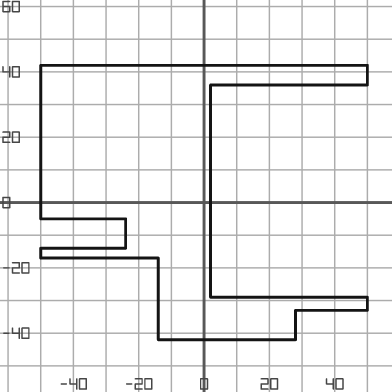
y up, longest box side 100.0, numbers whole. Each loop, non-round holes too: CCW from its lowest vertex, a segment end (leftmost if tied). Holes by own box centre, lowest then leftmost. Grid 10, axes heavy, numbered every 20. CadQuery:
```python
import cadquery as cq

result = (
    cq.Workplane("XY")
    .moveTo(-14.0, -42.0)
    .lineTo(28.0, -42.0)
    .lineTo(28.0, -33.0)
    .lineTo(50.0, -33.0)
    .lineTo(50.0, -29.0)
    .lineTo(2.0, -29.0)
    .lineTo(2.0, 36.0)
    .lineTo(50.0, 36.0)
    .lineTo(50.0, 42.0)
    .lineTo(-50.0, 42.0)
    .lineTo(-50.0, -5.0)
    .lineTo(-24.0, -5.0)
    .lineTo(-24.0, -14.0)
    .lineTo(-50.0, -14.0)
    .lineTo(-50.0, -17.0)
    .lineTo(-14.0, -17.0)
    .close()
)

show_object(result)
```